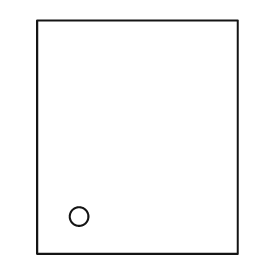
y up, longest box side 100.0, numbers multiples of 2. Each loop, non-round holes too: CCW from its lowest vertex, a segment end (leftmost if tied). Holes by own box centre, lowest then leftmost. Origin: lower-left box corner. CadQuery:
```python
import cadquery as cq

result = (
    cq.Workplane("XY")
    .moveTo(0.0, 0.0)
    .lineTo(86.0, 0.0)
    .lineTo(86.0, 100.0)
    .lineTo(0.0, 100.0)
    .close()
    .moveTo(18.0, 16.0)
    .circle(4.0)
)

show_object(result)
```